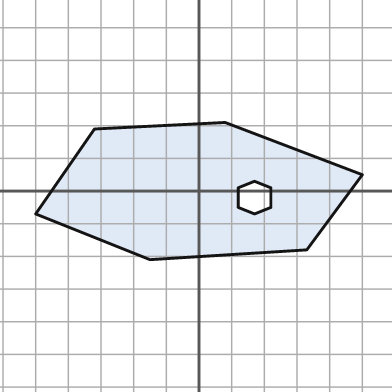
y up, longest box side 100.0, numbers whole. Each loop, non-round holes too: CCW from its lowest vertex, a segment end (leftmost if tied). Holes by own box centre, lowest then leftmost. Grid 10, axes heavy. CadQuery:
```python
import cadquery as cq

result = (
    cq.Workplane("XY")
    .moveTo(-15.0, -21.0)
    .lineTo(33.0, -18.0)
    .lineTo(50.0, 5.0)
    .lineTo(8.0, 21.0)
    .lineTo(-32.0, 19.0)
    .lineTo(-50.0, -7.0)
    .close()
    .moveTo(17.0, -7.0)
    .lineTo(22.0, -5.0)
    .lineTo(22.0, 1.0)
    .lineTo(17.0, 3.0)
    .lineTo(12.0, 1.0)
    .lineTo(12.0, -5.0)
    .close()
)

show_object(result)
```